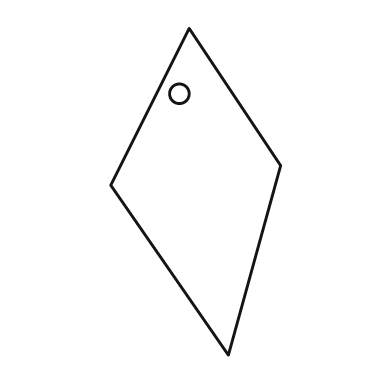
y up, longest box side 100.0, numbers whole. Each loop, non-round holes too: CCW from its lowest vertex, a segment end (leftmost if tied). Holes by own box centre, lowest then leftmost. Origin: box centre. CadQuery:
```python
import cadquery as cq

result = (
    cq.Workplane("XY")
    .moveTo(10.0, -50.0)
    .lineTo(26.0, 8.0)
    .lineTo(-2.0, 50.0)
    .lineTo(-26.0, 2.0)
    .close()
    .moveTo(-5.0, 30.0)
    .circle(3.0)
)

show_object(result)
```